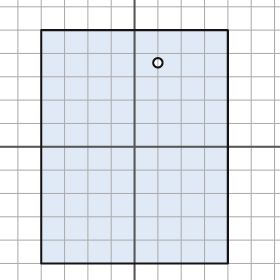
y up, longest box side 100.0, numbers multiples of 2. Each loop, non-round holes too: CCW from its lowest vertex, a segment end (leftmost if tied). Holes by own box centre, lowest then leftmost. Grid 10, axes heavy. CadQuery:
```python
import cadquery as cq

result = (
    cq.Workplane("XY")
    .moveTo(-40.0, -50.0)
    .lineTo(40.0, -50.0)
    .lineTo(40.0, 50.0)
    .lineTo(-40.0, 50.0)
    .close()
    .moveTo(10.0, 36.0)
    .circle(2.0)
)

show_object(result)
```